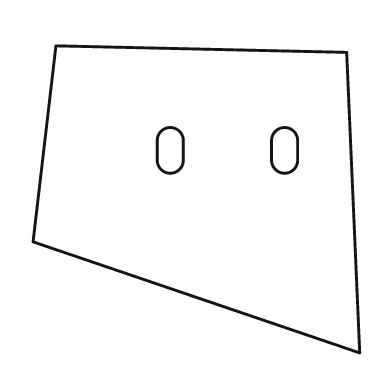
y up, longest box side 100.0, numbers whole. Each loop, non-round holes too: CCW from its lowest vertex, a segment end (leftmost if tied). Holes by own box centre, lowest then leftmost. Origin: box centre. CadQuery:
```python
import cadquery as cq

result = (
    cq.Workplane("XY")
    .moveTo(50.0, -47.0)
    .lineTo(46.0, 45.0)
    .lineTo(-43.0, 47.0)
    .lineTo(-50.0, -13.0)
    .close()
    .moveTo(-12.0, 12.0)
    .threePointArc((-8.0, 8.0), (-4.0, 12.0))
    .lineTo(-4.0, 18.0)
    .threePointArc((-8.0, 22.0), (-12.0, 18.0))
    .close()
    .moveTo(23.0, 12.0)
    .threePointArc((27.0, 8.0), (31.0, 12.0))
    .lineTo(31.0, 18.0)
    .threePointArc((27.0, 22.0), (23.0, 18.0))
    .close()
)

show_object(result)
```